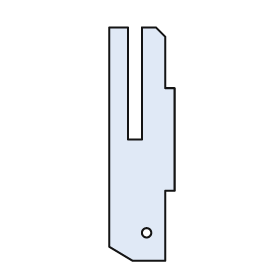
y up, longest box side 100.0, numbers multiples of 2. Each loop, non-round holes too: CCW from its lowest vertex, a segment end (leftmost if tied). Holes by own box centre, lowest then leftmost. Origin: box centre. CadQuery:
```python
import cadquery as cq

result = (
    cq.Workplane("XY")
    .moveTo(-4.0, -50.0)
    .lineTo(10.0, -50.0)
    .lineTo(10.0, -20.0)
    .lineTo(14.0, -20.0)
    .lineTo(14.0, 24.0)
    .lineTo(10.0, 24.0)
    .lineTo(10.0, 46.0)
    .lineTo(6.0, 50.0)
    .lineTo(0.0, 50.0)
    .lineTo(0.0, 2.0)
    .lineTo(-6.0, 2.0)
    .lineTo(-6.0, 50.0)
    .lineTo(-14.0, 50.0)
    .lineTo(-14.0, -44.0)
    .close()
    .moveTo(2.0, -38.0)
    .circle(2.0)
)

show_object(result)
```